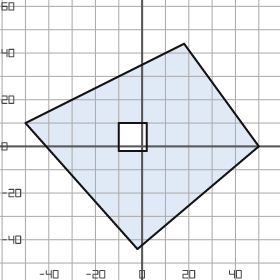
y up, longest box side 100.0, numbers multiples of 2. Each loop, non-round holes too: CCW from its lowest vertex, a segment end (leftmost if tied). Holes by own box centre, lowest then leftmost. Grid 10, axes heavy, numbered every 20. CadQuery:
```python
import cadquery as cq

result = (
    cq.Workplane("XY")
    .moveTo(-2.0, -44.0)
    .lineTo(50.0, 0.0)
    .lineTo(18.0, 44.0)
    .lineTo(-50.0, 10.0)
    .close()
    .moveTo(-10.0, -2.0)
    .lineTo(2.0, -2.0)
    .lineTo(2.0, 10.0)
    .lineTo(-10.0, 10.0)
    .close()
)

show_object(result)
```